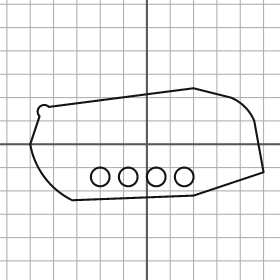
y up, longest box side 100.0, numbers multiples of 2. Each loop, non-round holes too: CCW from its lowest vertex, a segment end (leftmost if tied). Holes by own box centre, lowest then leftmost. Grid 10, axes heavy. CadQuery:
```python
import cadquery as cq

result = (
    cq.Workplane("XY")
    .moveTo(-32.0, -24.0)
    .lineTo(20.0, -22.0)
    .lineTo(50.0, -12.0)
    .lineTo(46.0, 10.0)
    .threePointArc((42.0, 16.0), (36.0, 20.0))
    .lineTo(20.0, 24.0)
    .lineTo(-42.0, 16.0)
    .threePointArc((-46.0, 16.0), (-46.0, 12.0))
    .lineTo(-50.0, 0.0)
    .threePointArc((-44.0, -14.0), (-32.0, -24.0))
    .close()
    .moveTo(-20.0, -14.0)
    .circle(4.0)
    .moveTo(-8.0, -14.0)
    .circle(4.0)
    .moveTo(4.0, -14.0)
    .circle(4.0)
    .moveTo(16.0, -14.0)
    .circle(4.0)
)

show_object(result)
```